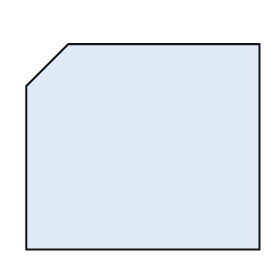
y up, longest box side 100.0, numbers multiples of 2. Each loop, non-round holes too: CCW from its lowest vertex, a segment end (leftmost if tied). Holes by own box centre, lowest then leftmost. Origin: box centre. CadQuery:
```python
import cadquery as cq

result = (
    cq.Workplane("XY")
    .moveTo(-50.0, -44.0)
    .lineTo(50.0, -44.0)
    .lineTo(50.0, 44.0)
    .lineTo(-32.0, 44.0)
    .lineTo(-50.0, 26.0)
    .close()
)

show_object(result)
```